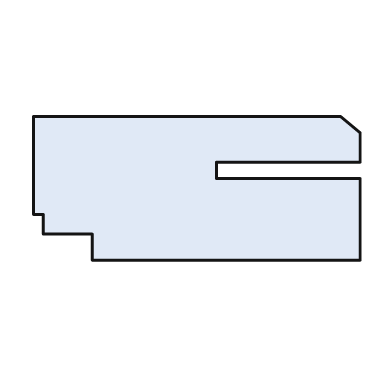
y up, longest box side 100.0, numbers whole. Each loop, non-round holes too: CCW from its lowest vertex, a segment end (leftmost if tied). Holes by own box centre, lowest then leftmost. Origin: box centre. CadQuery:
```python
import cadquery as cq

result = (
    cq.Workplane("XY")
    .moveTo(-32.0, -22.0)
    .lineTo(50.0, -22.0)
    .lineTo(50.0, 3.0)
    .lineTo(6.0, 3.0)
    .lineTo(6.0, 8.0)
    .lineTo(50.0, 8.0)
    .lineTo(50.0, 17.0)
    .lineTo(44.0, 22.0)
    .lineTo(-50.0, 22.0)
    .lineTo(-50.0, -8.0)
    .lineTo(-47.0, -8.0)
    .lineTo(-47.0, -14.0)
    .lineTo(-32.0, -14.0)
    .close()
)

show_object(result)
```